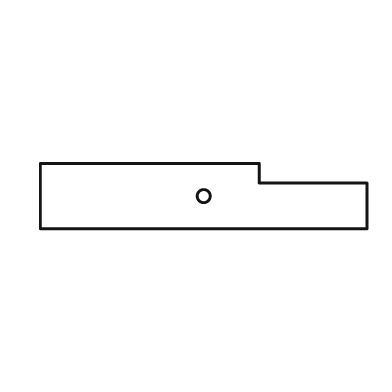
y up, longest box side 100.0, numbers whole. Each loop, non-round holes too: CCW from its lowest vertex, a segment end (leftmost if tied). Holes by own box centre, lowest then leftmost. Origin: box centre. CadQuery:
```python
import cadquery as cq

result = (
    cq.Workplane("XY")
    .moveTo(-50.0, -10.0)
    .lineTo(50.0, -10.0)
    .lineTo(50.0, 4.0)
    .lineTo(17.0, 4.0)
    .lineTo(17.0, 10.0)
    .lineTo(-50.0, 10.0)
    .close()
    .moveTo(0.0, 0.0)
    .circle(2.0)
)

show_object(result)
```